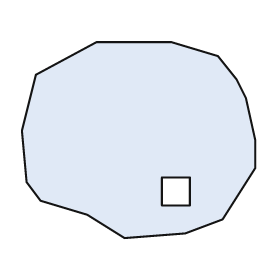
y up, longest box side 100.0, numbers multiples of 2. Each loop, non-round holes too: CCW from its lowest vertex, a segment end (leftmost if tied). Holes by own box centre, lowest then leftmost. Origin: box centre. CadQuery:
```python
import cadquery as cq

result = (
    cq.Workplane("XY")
    .moveTo(-6.0, -42.0)
    .lineTo(20.0, -40.0)
    .lineTo(36.0, -34.0)
    .lineTo(50.0, -12.0)
    .lineTo(50.0, 0.0)
    .lineTo(46.0, 18.0)
    .lineTo(42.0, 26.0)
    .lineTo(34.0, 36.0)
    .lineTo(14.0, 42.0)
    .lineTo(-18.0, 42.0)
    .lineTo(-44.0, 28.0)
    .lineTo(-50.0, 4.0)
    .lineTo(-48.0, -18.0)
    .lineTo(-42.0, -26.0)
    .lineTo(-22.0, -32.0)
    .close()
    .moveTo(10.0, -28.0)
    .lineTo(22.0, -28.0)
    .lineTo(22.0, -16.0)
    .lineTo(10.0, -16.0)
    .close()
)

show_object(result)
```